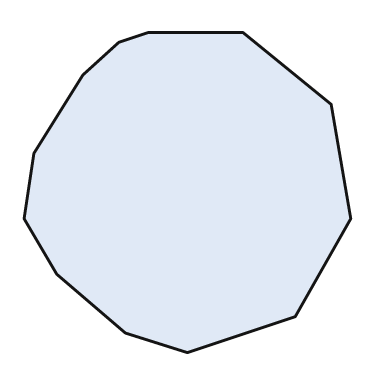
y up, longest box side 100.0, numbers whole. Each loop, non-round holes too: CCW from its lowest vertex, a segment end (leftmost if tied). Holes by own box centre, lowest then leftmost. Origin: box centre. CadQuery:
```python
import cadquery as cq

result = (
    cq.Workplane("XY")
    .moveTo(0.0, -49.0)
    .lineTo(33.0, -38.0)
    .lineTo(50.0, -8.0)
    .lineTo(44.0, 27.0)
    .lineTo(17.0, 49.0)
    .lineTo(-12.0, 49.0)
    .lineTo(-21.0, 46.0)
    .lineTo(-32.0, 36.0)
    .lineTo(-47.0, 12.0)
    .lineTo(-50.0, -8.0)
    .lineTo(-40.0, -25.0)
    .lineTo(-19.0, -43.0)
    .close()
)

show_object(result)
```